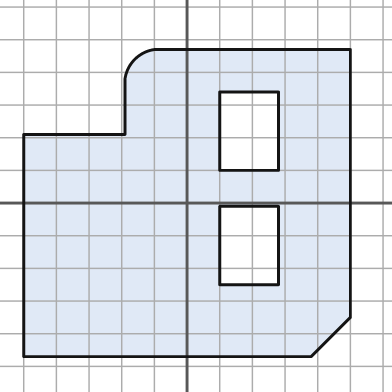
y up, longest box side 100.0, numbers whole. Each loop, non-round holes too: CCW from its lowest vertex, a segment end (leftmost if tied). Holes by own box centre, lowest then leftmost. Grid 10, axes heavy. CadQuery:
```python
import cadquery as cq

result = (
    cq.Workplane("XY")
    .moveTo(-50.0, -47.0)
    .lineTo(38.0, -47.0)
    .lineTo(50.0, -35.0)
    .lineTo(50.0, 47.0)
    .lineTo(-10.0, 47.0)
    .threePointArc((-16.0, 44.0), (-19.0, 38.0))
    .lineTo(-19.0, 21.0)
    .lineTo(-50.0, 21.0)
    .close()
    .moveTo(10.0, -25.0)
    .lineTo(28.0, -25.0)
    .lineTo(28.0, -1.0)
    .lineTo(10.0, -1.0)
    .close()
    .moveTo(10.0, 10.0)
    .lineTo(28.0, 10.0)
    .lineTo(28.0, 34.0)
    .lineTo(10.0, 34.0)
    .close()
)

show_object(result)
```